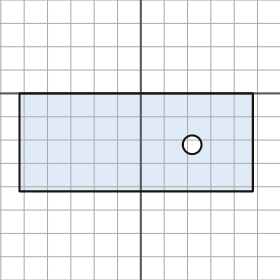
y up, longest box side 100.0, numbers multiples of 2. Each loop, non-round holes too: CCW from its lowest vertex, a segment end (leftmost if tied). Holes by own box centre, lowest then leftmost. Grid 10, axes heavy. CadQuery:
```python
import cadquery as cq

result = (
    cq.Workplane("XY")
    .moveTo(-52.0, -42.0)
    .lineTo(48.0, -42.0)
    .lineTo(48.0, 0.0)
    .lineTo(-52.0, 0.0)
    .close()
    .moveTo(22.0, -22.0)
    .circle(4.0)
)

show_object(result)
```